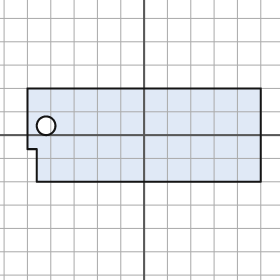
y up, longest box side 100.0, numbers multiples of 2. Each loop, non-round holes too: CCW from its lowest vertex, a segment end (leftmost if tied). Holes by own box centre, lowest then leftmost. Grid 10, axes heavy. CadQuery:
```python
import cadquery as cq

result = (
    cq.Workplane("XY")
    .moveTo(-46.0, -20.0)
    .lineTo(50.0, -20.0)
    .lineTo(50.0, 20.0)
    .lineTo(-50.0, 20.0)
    .lineTo(-50.0, -6.0)
    .lineTo(-46.0, -6.0)
    .close()
    .moveTo(-42.0, 4.0)
    .circle(4.0)
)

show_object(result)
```